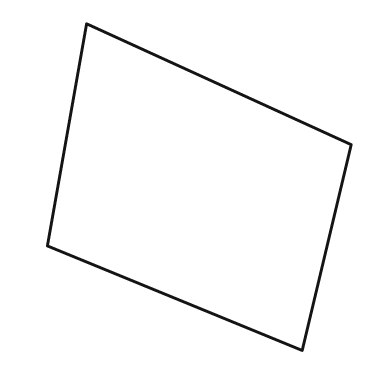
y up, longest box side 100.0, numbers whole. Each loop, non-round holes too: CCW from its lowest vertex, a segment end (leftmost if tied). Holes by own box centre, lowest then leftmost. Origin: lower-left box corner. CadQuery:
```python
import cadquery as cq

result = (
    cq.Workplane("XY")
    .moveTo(78.0, 0.0)
    .lineTo(93.0, 63.0)
    .lineTo(12.0, 100.0)
    .lineTo(0.0, 32.0)
    .close()
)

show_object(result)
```